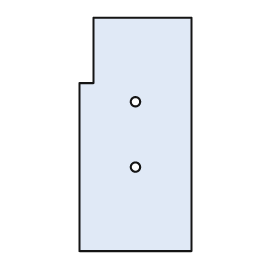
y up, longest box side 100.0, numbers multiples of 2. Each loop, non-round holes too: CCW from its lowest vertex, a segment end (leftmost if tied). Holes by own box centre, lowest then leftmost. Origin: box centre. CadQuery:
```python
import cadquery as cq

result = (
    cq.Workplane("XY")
    .moveTo(-24.0, -50.0)
    .lineTo(24.0, -50.0)
    .lineTo(24.0, 50.0)
    .lineTo(-18.0, 50.0)
    .lineTo(-18.0, 22.0)
    .lineTo(-24.0, 22.0)
    .close()
    .moveTo(0.0, -14.0)
    .circle(2.0)
    .moveTo(0.0, 14.0)
    .circle(2.0)
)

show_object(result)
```